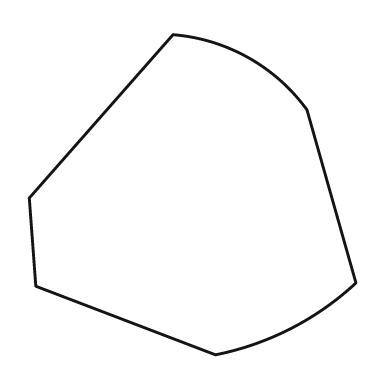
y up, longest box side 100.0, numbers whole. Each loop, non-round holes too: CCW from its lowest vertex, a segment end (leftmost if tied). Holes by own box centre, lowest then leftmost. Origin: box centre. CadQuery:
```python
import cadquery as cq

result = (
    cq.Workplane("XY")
    .moveTo(7.0, -49.0)
    .threePointArc((30.0, -41.0), (50.0, -27.0))
    .lineTo(35.0, 26.0)
    .threePointArc((17.0, 42.0), (-6.0, 49.0))
    .lineTo(-50.0, -1.0)
    .lineTo(-48.0, -28.0)
    .close()
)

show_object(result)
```